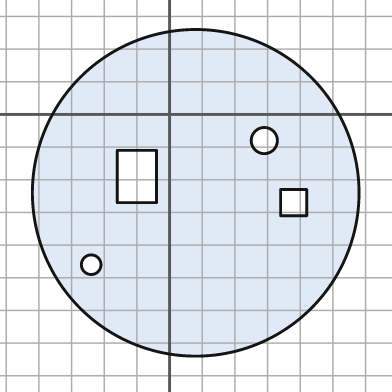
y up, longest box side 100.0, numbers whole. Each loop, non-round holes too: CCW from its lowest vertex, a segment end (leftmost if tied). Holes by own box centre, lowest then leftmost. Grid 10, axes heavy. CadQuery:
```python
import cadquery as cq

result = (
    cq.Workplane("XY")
    .moveTo(8.0, -24.0)
    .circle(50.0)
    .moveTo(-24.0, -46.0)
    .circle(3.0)
    .moveTo(34.0, -31.0)
    .lineTo(42.0, -31.0)
    .lineTo(42.0, -23.0)
    .lineTo(34.0, -23.0)
    .close()
    .moveTo(-16.0, -27.0)
    .lineTo(-4.0, -27.0)
    .lineTo(-4.0, -11.0)
    .lineTo(-16.0, -11.0)
    .close()
    .moveTo(29.0, -8.0)
    .circle(4.0)
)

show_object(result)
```